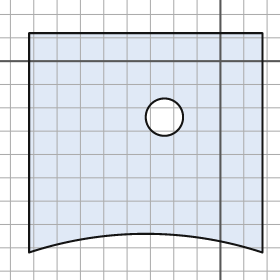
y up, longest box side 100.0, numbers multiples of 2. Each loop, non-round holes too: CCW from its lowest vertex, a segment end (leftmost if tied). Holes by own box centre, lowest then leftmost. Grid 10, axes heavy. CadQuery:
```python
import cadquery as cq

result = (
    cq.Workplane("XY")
    .moveTo(-82.0, -82.0)
    .threePointArc((-32.0, -74.0), (18.0, -82.0))
    .lineTo(18.0, 12.0)
    .lineTo(-82.0, 12.0)
    .close()
    .moveTo(-24.0, -24.0)
    .circle(8.0)
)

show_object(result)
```